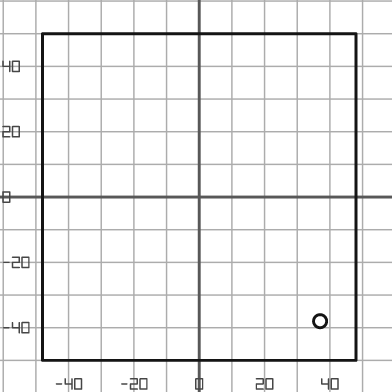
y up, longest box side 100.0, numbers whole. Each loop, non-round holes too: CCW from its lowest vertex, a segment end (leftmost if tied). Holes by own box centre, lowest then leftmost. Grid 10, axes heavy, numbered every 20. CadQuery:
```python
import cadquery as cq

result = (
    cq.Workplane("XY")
    .moveTo(-48.0, -50.0)
    .lineTo(48.0, -50.0)
    .lineTo(48.0, 50.0)
    .lineTo(-48.0, 50.0)
    .close()
    .moveTo(37.0, -38.0)
    .circle(2.0)
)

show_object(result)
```